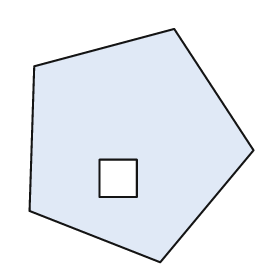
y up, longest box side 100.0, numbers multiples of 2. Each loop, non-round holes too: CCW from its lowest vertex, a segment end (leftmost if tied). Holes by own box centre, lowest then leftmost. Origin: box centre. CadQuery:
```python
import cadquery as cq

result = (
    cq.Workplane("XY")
    .moveTo(8.0, -50.0)
    .lineTo(48.0, -2.0)
    .lineTo(14.0, 50.0)
    .lineTo(-46.0, 34.0)
    .lineTo(-48.0, -28.0)
    .close()
    .moveTo(-18.0, -22.0)
    .lineTo(-2.0, -22.0)
    .lineTo(-2.0, -6.0)
    .lineTo(-18.0, -6.0)
    .close()
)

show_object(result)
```